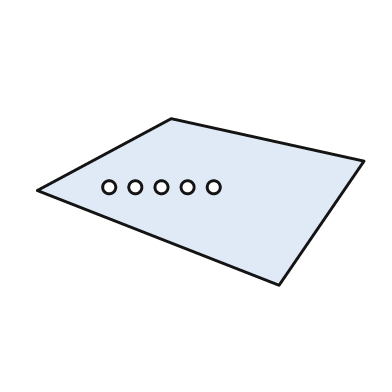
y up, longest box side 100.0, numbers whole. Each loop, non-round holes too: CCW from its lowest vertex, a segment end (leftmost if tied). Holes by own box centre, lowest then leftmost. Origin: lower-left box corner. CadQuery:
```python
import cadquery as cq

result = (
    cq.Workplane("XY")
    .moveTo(74.0, 0.0)
    .lineTo(100.0, 38.0)
    .lineTo(41.0, 51.0)
    .lineTo(0.0, 29.0)
    .close()
    .moveTo(22.0, 30.0)
    .circle(2.0)
    .moveTo(30.0, 30.0)
    .circle(2.0)
    .moveTo(38.0, 30.0)
    .circle(2.0)
    .moveTo(46.0, 30.0)
    .circle(2.0)
    .moveTo(54.0, 30.0)
    .circle(2.0)
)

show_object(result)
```